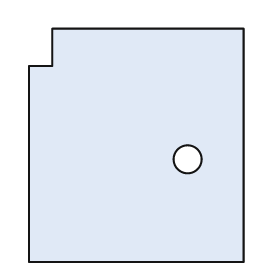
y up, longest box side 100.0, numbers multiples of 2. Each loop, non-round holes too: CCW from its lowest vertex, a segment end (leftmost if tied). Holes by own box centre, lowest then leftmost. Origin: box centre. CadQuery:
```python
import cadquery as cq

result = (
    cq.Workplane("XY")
    .moveTo(-46.0, -50.0)
    .lineTo(46.0, -50.0)
    .lineTo(46.0, 50.0)
    .lineTo(-36.0, 50.0)
    .lineTo(-36.0, 34.0)
    .lineTo(-46.0, 34.0)
    .close()
    .moveTo(22.0, -6.0)
    .circle(6.0)
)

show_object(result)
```